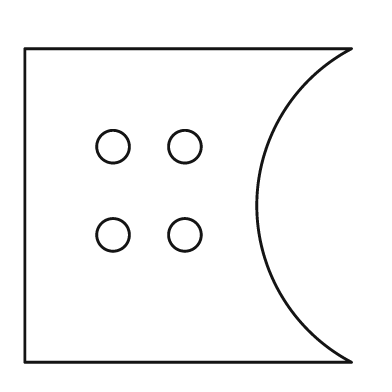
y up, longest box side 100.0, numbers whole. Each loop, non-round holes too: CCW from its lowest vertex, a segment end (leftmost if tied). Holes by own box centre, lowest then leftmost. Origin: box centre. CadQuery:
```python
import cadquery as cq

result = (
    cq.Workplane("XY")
    .moveTo(-50.0, -48.0)
    .lineTo(50.0, -48.0)
    .threePointArc((21.0, 0.0), (50.0, 48.0))
    .lineTo(-50.0, 48.0)
    .close()
    .moveTo(-23.0, -9.0)
    .circle(5.0)
    .moveTo(-1.0, -9.0)
    .circle(5.0)
    .moveTo(-23.0, 18.0)
    .circle(5.0)
    .moveTo(-1.0, 18.0)
    .circle(5.0)
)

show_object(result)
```